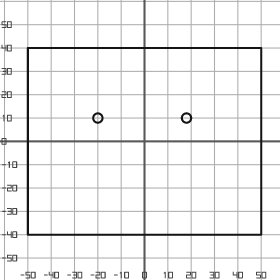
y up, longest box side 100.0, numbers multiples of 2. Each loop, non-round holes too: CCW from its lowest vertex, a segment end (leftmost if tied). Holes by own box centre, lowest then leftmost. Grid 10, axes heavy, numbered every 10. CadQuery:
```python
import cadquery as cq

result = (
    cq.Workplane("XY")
    .moveTo(-50.0, -40.0)
    .lineTo(50.0, -40.0)
    .lineTo(50.0, 40.0)
    .lineTo(-50.0, 40.0)
    .close()
    .moveTo(-20.0, 10.0)
    .circle(2.0)
    .moveTo(18.0, 10.0)
    .circle(2.0)
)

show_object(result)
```